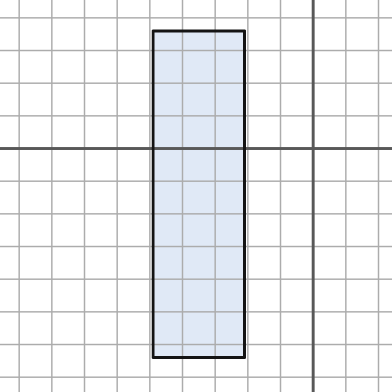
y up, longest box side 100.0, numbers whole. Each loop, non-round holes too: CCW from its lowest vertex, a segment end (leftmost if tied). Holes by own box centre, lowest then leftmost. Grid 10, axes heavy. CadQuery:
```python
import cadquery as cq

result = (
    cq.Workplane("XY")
    .moveTo(-49.0, -64.0)
    .lineTo(-21.0, -64.0)
    .lineTo(-21.0, 36.0)
    .lineTo(-49.0, 36.0)
    .close()
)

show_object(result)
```